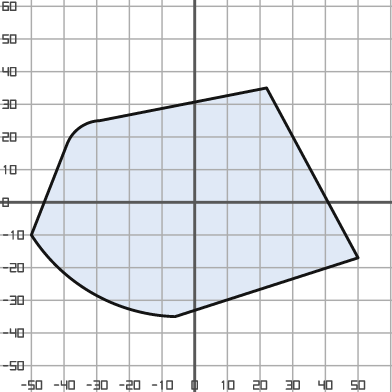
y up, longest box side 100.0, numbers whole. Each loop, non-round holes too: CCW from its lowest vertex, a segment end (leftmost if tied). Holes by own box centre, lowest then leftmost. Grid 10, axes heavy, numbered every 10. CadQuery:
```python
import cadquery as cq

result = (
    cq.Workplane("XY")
    .moveTo(-6.0, -35.0)
    .lineTo(50.0, -17.0)
    .lineTo(22.0, 35.0)
    .lineTo(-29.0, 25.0)
    .threePointArc((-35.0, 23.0), (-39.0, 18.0))
    .lineTo(-50.0, -10.0)
    .threePointArc((-31.0, -28.0), (-6.0, -35.0))
    .close()
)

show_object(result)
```